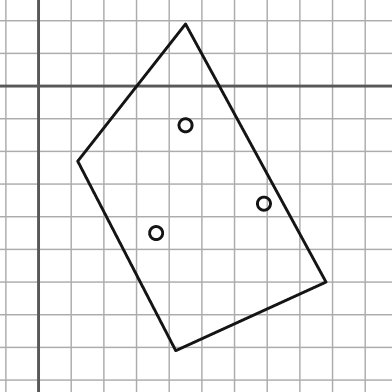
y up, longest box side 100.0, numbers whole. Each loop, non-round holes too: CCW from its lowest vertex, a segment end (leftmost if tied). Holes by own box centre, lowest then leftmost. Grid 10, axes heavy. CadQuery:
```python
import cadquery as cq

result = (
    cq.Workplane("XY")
    .moveTo(42.0, -81.0)
    .lineTo(88.0, -60.0)
    .lineTo(45.0, 19.0)
    .lineTo(12.0, -23.0)
    .close()
    .moveTo(36.0, -45.0)
    .circle(2.0)
    .moveTo(69.0, -36.0)
    .circle(2.0)
    .moveTo(45.0, -12.0)
    .circle(2.0)
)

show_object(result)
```